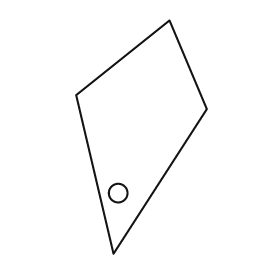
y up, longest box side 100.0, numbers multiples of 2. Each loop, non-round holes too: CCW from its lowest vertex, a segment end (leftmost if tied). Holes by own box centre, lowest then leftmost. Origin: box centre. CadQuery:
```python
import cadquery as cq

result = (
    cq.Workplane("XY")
    .moveTo(-12.0, -50.0)
    .lineTo(28.0, 12.0)
    .lineTo(12.0, 50.0)
    .lineTo(-28.0, 18.0)
    .close()
    .moveTo(-10.0, -24.0)
    .circle(4.0)
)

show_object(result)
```